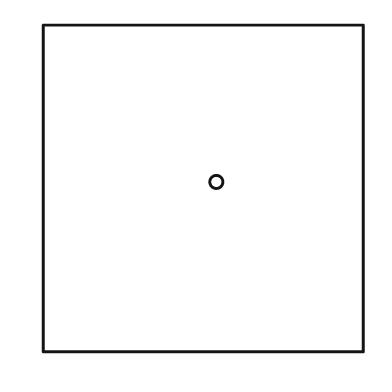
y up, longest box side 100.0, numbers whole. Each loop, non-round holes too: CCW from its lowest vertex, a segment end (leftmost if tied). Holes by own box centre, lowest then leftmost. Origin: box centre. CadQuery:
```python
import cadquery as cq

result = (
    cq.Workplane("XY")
    .moveTo(-49.0, -50.0)
    .lineTo(49.0, -50.0)
    .lineTo(49.0, 50.0)
    .lineTo(-49.0, 50.0)
    .close()
    .moveTo(4.0, 2.0)
    .circle(2.0)
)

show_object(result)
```